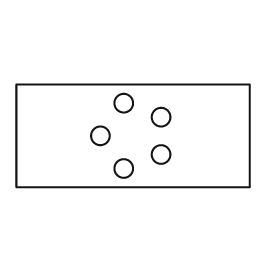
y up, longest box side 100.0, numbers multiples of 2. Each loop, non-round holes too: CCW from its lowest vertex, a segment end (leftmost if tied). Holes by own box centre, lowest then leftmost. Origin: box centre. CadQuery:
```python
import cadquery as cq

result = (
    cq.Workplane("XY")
    .moveTo(-50.0, -22.0)
    .lineTo(50.0, -22.0)
    .lineTo(50.0, 22.0)
    .lineTo(-50.0, 22.0)
    .close()
    .moveTo(-4.0, -14.0)
    .circle(4.0)
    .moveTo(12.0, -8.0)
    .circle(4.0)
    .moveTo(-14.0, 0.0)
    .circle(4.0)
    .moveTo(12.0, 8.0)
    .circle(4.0)
    .moveTo(-4.0, 14.0)
    .circle(4.0)
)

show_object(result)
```